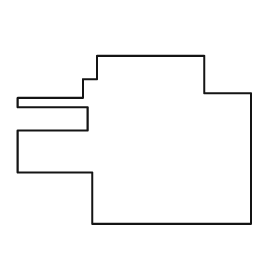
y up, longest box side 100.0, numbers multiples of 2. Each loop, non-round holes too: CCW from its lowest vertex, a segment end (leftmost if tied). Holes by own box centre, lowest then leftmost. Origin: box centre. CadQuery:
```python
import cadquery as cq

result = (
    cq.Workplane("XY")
    .moveTo(-18.0, -36.0)
    .lineTo(50.0, -36.0)
    .lineTo(50.0, 20.0)
    .lineTo(30.0, 20.0)
    .lineTo(30.0, 36.0)
    .lineTo(-16.0, 36.0)
    .lineTo(-16.0, 26.0)
    .lineTo(-22.0, 26.0)
    .lineTo(-22.0, 18.0)
    .lineTo(-50.0, 18.0)
    .lineTo(-50.0, 14.0)
    .lineTo(-20.0, 14.0)
    .lineTo(-20.0, 4.0)
    .lineTo(-50.0, 4.0)
    .lineTo(-50.0, -14.0)
    .lineTo(-18.0, -14.0)
    .close()
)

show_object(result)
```